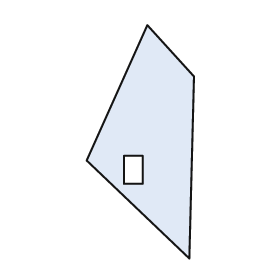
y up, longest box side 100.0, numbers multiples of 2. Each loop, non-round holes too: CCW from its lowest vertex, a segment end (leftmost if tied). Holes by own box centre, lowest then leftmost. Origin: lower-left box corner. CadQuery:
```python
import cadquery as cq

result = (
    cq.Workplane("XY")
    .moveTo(44.0, 0.0)
    .lineTo(46.0, 78.0)
    .lineTo(26.0, 100.0)
    .lineTo(0.0, 42.0)
    .close()
    .moveTo(16.0, 32.0)
    .lineTo(24.0, 32.0)
    .lineTo(24.0, 44.0)
    .lineTo(16.0, 44.0)
    .close()
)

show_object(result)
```